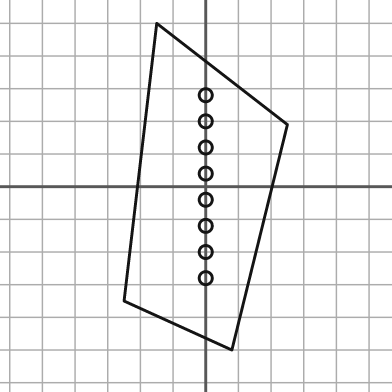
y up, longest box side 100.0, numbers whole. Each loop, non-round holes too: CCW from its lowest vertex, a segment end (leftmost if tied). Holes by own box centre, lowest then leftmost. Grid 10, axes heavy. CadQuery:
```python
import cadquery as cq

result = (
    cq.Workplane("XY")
    .moveTo(8.0, -50.0)
    .lineTo(25.0, 19.0)
    .lineTo(-15.0, 50.0)
    .lineTo(-25.0, -35.0)
    .close()
    .moveTo(0.0, -28.0)
    .circle(2.0)
    .moveTo(0.0, -20.0)
    .circle(2.0)
    .moveTo(0.0, -12.0)
    .circle(2.0)
    .moveTo(0.0, -4.0)
    .circle(2.0)
    .moveTo(0.0, 4.0)
    .circle(2.0)
    .moveTo(0.0, 12.0)
    .circle(2.0)
    .moveTo(0.0, 20.0)
    .circle(2.0)
    .moveTo(0.0, 28.0)
    .circle(2.0)
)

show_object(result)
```